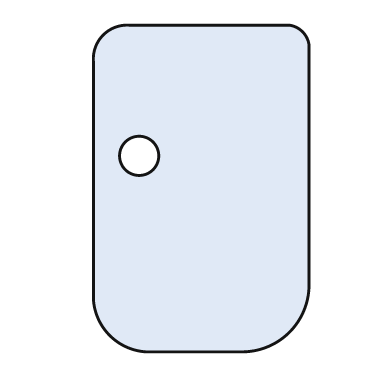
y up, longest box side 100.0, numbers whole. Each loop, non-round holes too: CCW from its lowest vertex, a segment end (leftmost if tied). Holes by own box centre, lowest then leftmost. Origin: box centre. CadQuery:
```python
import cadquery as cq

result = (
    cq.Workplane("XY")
    .moveTo(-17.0, -50.0)
    .lineTo(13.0, -50.0)
    .threePointArc((27.0, -44.0), (33.0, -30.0))
    .lineTo(33.0, 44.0)
    .threePointArc((31.0, 48.0), (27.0, 50.0))
    .lineTo(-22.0, 50.0)
    .threePointArc((-30.0, 47.0), (-33.0, 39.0))
    .lineTo(-33.0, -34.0)
    .threePointArc((-28.0, -45.0), (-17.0, -50.0))
    .close()
    .moveTo(-19.0, 10.0)
    .circle(6.0)
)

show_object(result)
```